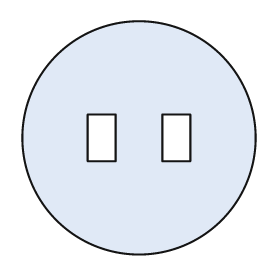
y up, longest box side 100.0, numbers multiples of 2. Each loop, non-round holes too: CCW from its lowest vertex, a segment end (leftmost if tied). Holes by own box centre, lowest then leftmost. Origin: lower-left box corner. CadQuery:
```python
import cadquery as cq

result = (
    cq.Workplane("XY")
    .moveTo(50.0, 50.0)
    .circle(50.0)
    .moveTo(28.0, 40.0)
    .lineTo(40.0, 40.0)
    .lineTo(40.0, 60.0)
    .lineTo(28.0, 60.0)
    .close()
    .moveTo(60.0, 40.0)
    .lineTo(72.0, 40.0)
    .lineTo(72.0, 60.0)
    .lineTo(60.0, 60.0)
    .close()
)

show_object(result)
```